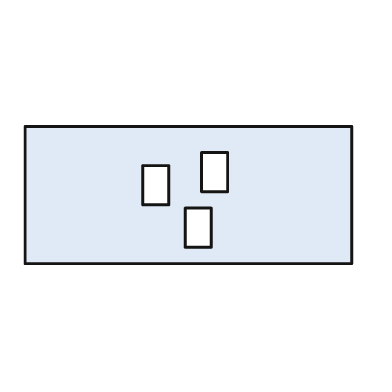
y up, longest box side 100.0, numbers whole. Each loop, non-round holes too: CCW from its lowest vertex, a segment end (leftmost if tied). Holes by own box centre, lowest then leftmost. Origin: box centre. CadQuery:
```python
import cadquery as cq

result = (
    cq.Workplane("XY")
    .moveTo(-50.0, -21.0)
    .lineTo(50.0, -21.0)
    .lineTo(50.0, 21.0)
    .lineTo(-50.0, 21.0)
    .close()
    .moveTo(-1.0, -16.0)
    .lineTo(7.0, -16.0)
    .lineTo(7.0, -4.0)
    .lineTo(-1.0, -4.0)
    .close()
    .moveTo(-14.0, -3.0)
    .lineTo(-6.0, -3.0)
    .lineTo(-6.0, 9.0)
    .lineTo(-14.0, 9.0)
    .close()
    .moveTo(4.0, 1.0)
    .lineTo(12.0, 1.0)
    .lineTo(12.0, 13.0)
    .lineTo(4.0, 13.0)
    .close()
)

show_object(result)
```